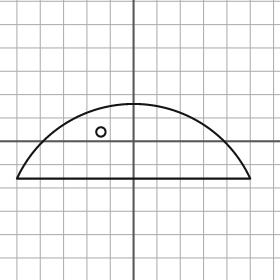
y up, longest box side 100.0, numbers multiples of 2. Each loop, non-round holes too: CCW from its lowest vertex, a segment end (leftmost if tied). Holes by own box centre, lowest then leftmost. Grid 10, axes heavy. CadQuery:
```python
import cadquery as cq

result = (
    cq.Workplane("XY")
    .moveTo(-50.0, -16.0)
    .lineTo(50.0, -16.0)
    .threePointArc((0.0, 16.0), (-50.0, -16.0))
    .close()
    .moveTo(-14.0, 4.0)
    .circle(2.0)
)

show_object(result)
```